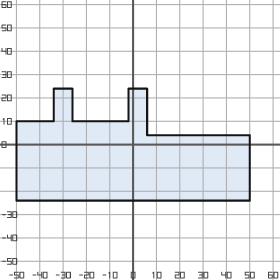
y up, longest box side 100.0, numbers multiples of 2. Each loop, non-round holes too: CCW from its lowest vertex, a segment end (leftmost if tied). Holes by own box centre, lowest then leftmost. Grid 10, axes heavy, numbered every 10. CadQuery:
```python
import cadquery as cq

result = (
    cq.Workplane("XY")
    .moveTo(-50.0, -24.0)
    .lineTo(50.0, -24.0)
    .lineTo(50.0, 4.0)
    .lineTo(6.0, 4.0)
    .lineTo(6.0, 24.0)
    .lineTo(-2.0, 24.0)
    .lineTo(-2.0, 10.0)
    .lineTo(-26.0, 10.0)
    .lineTo(-26.0, 24.0)
    .lineTo(-34.0, 24.0)
    .lineTo(-34.0, 10.0)
    .lineTo(-50.0, 10.0)
    .close()
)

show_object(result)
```